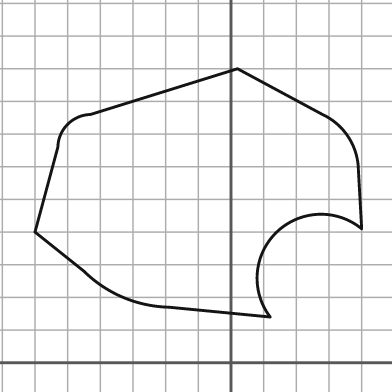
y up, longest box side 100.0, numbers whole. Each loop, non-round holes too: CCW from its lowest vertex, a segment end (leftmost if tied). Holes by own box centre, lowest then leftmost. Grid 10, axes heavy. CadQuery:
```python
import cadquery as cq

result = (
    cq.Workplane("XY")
    .moveTo(12.0, 14.0)
    .threePointArc((14.0, 40.0), (40.0, 41.0))
    .lineTo(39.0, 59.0)
    .threePointArc((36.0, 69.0), (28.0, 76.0))
    .lineTo(2.0, 90.0)
    .lineTo(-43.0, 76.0)
    .threePointArc((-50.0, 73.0), (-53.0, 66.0))
    .lineTo(-60.0, 40.0)
    .lineTo(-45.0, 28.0)
    .threePointArc((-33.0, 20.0), (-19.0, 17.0))
    .close()
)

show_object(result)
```